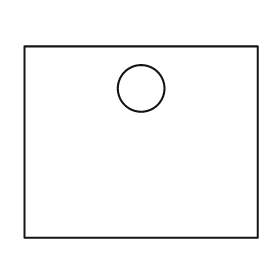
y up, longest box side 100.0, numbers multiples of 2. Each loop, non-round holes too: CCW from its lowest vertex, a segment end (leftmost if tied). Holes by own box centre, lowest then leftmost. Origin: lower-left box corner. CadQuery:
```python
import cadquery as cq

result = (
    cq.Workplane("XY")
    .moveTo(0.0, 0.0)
    .lineTo(100.0, 0.0)
    .lineTo(100.0, 82.0)
    .lineTo(0.0, 82.0)
    .close()
    .moveTo(50.0, 64.0)
    .circle(10.0)
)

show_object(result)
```